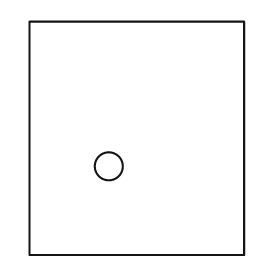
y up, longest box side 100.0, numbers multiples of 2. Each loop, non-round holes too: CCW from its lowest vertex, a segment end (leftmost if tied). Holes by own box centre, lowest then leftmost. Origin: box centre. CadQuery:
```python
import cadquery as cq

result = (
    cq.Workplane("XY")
    .moveTo(-46.0, -50.0)
    .lineTo(46.0, -50.0)
    .lineTo(46.0, 50.0)
    .lineTo(-46.0, 50.0)
    .close()
    .moveTo(-12.0, -12.0)
    .circle(6.0)
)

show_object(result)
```